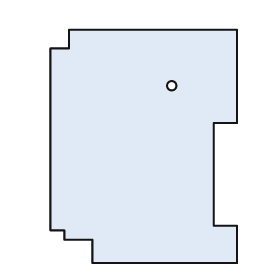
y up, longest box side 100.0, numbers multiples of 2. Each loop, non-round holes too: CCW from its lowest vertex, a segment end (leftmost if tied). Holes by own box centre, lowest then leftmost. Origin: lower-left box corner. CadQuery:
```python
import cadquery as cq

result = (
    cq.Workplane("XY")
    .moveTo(18.0, 0.0)
    .lineTo(80.0, 0.0)
    .lineTo(80.0, 16.0)
    .lineTo(70.0, 16.0)
    .lineTo(70.0, 60.0)
    .lineTo(80.0, 60.0)
    .lineTo(80.0, 100.0)
    .lineTo(8.0, 100.0)
    .lineTo(8.0, 92.0)
    .lineTo(0.0, 92.0)
    .lineTo(0.0, 14.0)
    .lineTo(6.0, 14.0)
    .lineTo(6.0, 10.0)
    .lineTo(18.0, 10.0)
    .close()
    .moveTo(52.0, 76.0)
    .circle(2.0)
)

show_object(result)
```